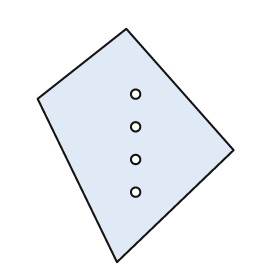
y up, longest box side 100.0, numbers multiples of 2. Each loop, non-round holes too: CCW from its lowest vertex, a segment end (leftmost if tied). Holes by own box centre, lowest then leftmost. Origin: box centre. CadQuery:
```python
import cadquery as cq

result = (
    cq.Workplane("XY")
    .moveTo(-8.0, -50.0)
    .lineTo(42.0, -2.0)
    .lineTo(-4.0, 50.0)
    .lineTo(-42.0, 20.0)
    .close()
    .moveTo(0.0, -20.0)
    .circle(2.0)
    .moveTo(0.0, -6.0)
    .circle(2.0)
    .moveTo(0.0, 8.0)
    .circle(2.0)
    .moveTo(0.0, 22.0)
    .circle(2.0)
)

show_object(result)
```